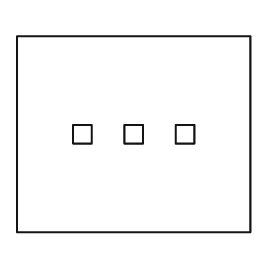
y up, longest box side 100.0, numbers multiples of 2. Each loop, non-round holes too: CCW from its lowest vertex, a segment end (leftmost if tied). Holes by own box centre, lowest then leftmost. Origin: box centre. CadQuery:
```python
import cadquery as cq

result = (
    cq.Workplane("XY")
    .moveTo(-50.0, -42.0)
    .lineTo(50.0, -42.0)
    .lineTo(50.0, 42.0)
    .lineTo(-50.0, 42.0)
    .close()
    .moveTo(-26.0, -4.0)
    .lineTo(-18.0, -4.0)
    .lineTo(-18.0, 4.0)
    .lineTo(-26.0, 4.0)
    .close()
    .moveTo(-4.0, -4.0)
    .lineTo(4.0, -4.0)
    .lineTo(4.0, 4.0)
    .lineTo(-4.0, 4.0)
    .close()
    .moveTo(18.0, -4.0)
    .lineTo(26.0, -4.0)
    .lineTo(26.0, 4.0)
    .lineTo(18.0, 4.0)
    .close()
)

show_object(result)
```